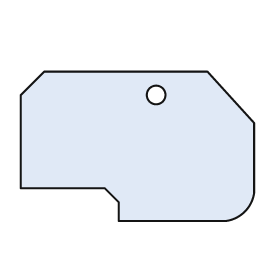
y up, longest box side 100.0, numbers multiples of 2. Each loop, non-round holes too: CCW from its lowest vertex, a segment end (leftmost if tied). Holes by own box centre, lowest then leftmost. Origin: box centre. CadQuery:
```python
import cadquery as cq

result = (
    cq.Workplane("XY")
    .moveTo(-8.0, -32.0)
    .lineTo(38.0, -32.0)
    .threePointArc((46.0, -28.0), (50.0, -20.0))
    .lineTo(50.0, 10.0)
    .lineTo(30.0, 32.0)
    .lineTo(-40.0, 32.0)
    .lineTo(-50.0, 22.0)
    .lineTo(-50.0, -18.0)
    .lineTo(-14.0, -18.0)
    .lineTo(-8.0, -24.0)
    .close()
    .moveTo(8.0, 22.0)
    .circle(4.0)
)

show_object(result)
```